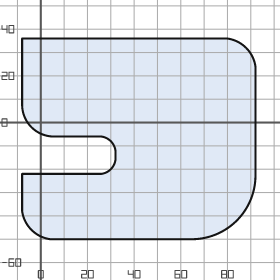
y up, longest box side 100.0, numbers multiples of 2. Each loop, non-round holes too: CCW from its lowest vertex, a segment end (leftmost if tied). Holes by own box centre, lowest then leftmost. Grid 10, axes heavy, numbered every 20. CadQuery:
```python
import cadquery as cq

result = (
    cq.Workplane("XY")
    .moveTo(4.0, -50.0)
    .lineTo(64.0, -50.0)
    .threePointArc((84.0, -42.0), (92.0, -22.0))
    .lineTo(92.0, 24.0)
    .threePointArc((88.0, 32.0), (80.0, 36.0))
    .lineTo(-8.0, 36.0)
    .lineTo(-8.0, 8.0)
    .threePointArc((-4.0, -2.0), (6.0, -6.0))
    .lineTo(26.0, -6.0)
    .threePointArc((30.0, -8.0), (32.0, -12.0))
    .lineTo(32.0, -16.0)
    .threePointArc((30.0, -20.0), (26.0, -22.0))
    .lineTo(-8.0, -22.0)
    .lineTo(-8.0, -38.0)
    .threePointArc((-4.0, -46.0), (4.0, -50.0))
    .close()
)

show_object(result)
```